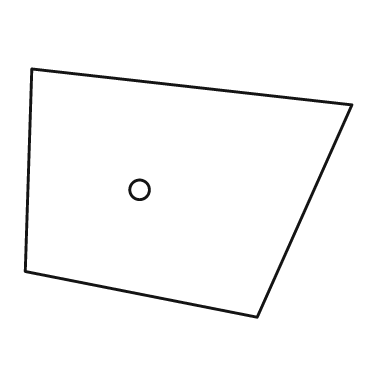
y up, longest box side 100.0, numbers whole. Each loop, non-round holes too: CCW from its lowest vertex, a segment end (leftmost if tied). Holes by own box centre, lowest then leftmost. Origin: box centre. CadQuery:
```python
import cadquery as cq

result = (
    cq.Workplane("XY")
    .moveTo(21.0, -38.0)
    .lineTo(50.0, 27.0)
    .lineTo(-48.0, 38.0)
    .lineTo(-50.0, -24.0)
    .close()
    .moveTo(-15.0, 1.0)
    .circle(3.0)
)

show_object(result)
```